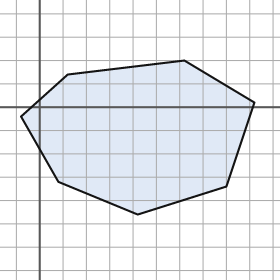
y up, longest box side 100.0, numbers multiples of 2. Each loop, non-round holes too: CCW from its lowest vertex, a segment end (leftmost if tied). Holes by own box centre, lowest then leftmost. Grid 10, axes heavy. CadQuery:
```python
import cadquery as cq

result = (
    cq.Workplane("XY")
    .moveTo(42.0, -46.0)
    .lineTo(80.0, -34.0)
    .lineTo(92.0, 2.0)
    .lineTo(62.0, 20.0)
    .lineTo(12.0, 14.0)
    .lineTo(-8.0, -4.0)
    .lineTo(8.0, -32.0)
    .close()
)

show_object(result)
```